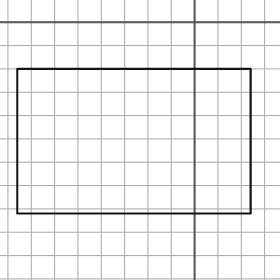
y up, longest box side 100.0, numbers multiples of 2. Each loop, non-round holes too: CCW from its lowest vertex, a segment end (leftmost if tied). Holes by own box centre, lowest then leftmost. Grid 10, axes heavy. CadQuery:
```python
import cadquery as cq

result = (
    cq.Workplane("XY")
    .moveTo(-76.0, -82.0)
    .lineTo(24.0, -82.0)
    .lineTo(24.0, -20.0)
    .lineTo(-76.0, -20.0)
    .close()
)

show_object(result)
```